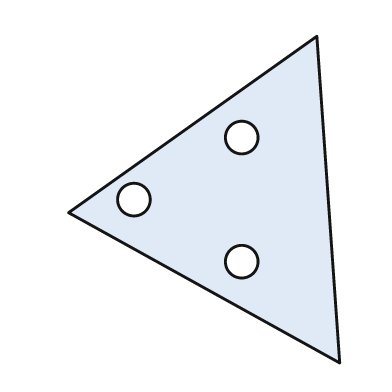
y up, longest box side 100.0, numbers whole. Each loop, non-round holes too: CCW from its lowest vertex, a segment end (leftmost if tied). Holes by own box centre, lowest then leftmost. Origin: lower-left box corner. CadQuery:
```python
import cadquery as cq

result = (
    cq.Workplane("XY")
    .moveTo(83.0, 0.0)
    .lineTo(76.0, 100.0)
    .lineTo(0.0, 46.0)
    .close()
    .moveTo(53.0, 31.0)
    .circle(5.0)
    .moveTo(20.0, 50.0)
    .circle(5.0)
    .moveTo(53.0, 69.0)
    .circle(5.0)
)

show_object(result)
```